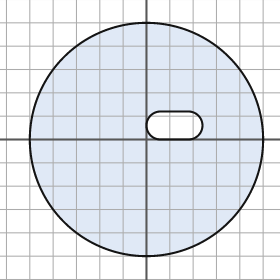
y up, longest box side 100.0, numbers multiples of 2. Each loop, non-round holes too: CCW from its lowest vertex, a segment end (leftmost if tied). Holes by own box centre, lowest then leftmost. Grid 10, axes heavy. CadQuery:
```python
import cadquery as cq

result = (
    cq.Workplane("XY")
    .moveTo(0.0, 0.0)
    .circle(50.0)
    .moveTo(6.0, 0.0)
    .lineTo(18.0, 0.0)
    .threePointArc((24.0, 6.0), (18.0, 12.0))
    .lineTo(6.0, 12.0)
    .threePointArc((0.0, 6.0), (6.0, 0.0))
    .close()
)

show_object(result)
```